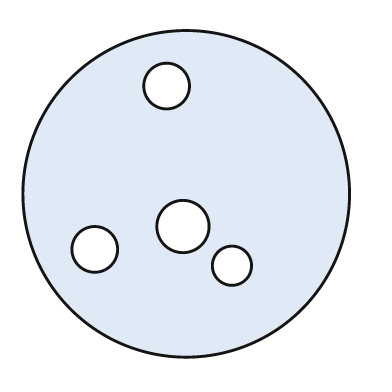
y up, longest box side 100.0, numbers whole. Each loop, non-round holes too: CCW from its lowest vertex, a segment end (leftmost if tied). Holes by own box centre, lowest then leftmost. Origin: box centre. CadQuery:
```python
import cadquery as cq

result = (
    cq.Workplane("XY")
    .moveTo(0.0, 0.0)
    .circle(50.0)
    .moveTo(14.0, -22.0)
    .circle(6.0)
    .moveTo(-28.0, -17.0)
    .circle(7.0)
    .moveTo(-1.0, -10.0)
    .circle(8.0)
    .moveTo(-6.0, 33.0)
    .circle(7.0)
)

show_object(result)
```